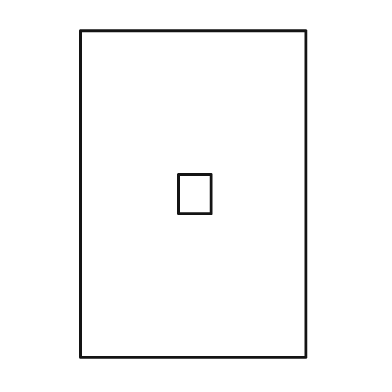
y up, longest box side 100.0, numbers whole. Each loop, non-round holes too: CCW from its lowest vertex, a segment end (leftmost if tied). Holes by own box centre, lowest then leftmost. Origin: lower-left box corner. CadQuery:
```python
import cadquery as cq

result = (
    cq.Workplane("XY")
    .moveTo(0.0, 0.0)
    .lineTo(69.0, 0.0)
    .lineTo(69.0, 100.0)
    .lineTo(0.0, 100.0)
    .close()
    .moveTo(30.0, 44.0)
    .lineTo(40.0, 44.0)
    .lineTo(40.0, 56.0)
    .lineTo(30.0, 56.0)
    .close()
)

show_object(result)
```